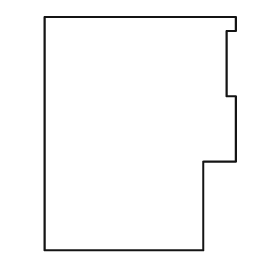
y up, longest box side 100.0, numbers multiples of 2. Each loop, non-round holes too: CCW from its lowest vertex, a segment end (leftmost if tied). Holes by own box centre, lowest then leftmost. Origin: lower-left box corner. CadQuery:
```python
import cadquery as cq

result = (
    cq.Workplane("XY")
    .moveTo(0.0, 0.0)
    .lineTo(68.0, 0.0)
    .lineTo(68.0, 38.0)
    .lineTo(82.0, 38.0)
    .lineTo(82.0, 66.0)
    .lineTo(78.0, 66.0)
    .lineTo(78.0, 94.0)
    .lineTo(82.0, 94.0)
    .lineTo(82.0, 100.0)
    .lineTo(0.0, 100.0)
    .close()
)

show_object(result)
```